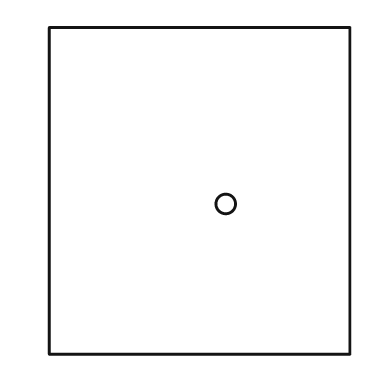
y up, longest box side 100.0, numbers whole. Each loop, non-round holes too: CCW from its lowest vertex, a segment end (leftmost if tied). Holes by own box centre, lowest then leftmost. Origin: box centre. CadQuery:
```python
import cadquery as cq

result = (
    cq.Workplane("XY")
    .moveTo(-46.0, -50.0)
    .lineTo(46.0, -50.0)
    .lineTo(46.0, 50.0)
    .lineTo(-46.0, 50.0)
    .close()
    .moveTo(8.0, -4.0)
    .circle(3.0)
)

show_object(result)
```